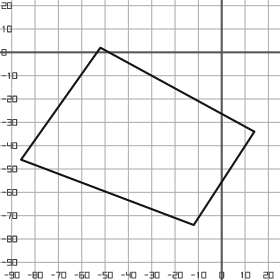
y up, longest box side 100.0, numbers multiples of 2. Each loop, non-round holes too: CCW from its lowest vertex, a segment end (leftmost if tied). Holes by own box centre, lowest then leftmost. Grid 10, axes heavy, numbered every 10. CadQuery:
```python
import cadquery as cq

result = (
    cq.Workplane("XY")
    .moveTo(-12.0, -74.0)
    .lineTo(14.0, -34.0)
    .lineTo(-52.0, 2.0)
    .lineTo(-86.0, -46.0)
    .close()
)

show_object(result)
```